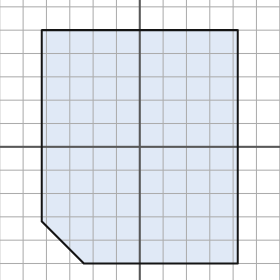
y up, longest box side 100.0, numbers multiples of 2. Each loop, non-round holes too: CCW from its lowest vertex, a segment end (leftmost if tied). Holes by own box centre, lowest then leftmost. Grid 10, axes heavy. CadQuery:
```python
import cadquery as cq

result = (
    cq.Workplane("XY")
    .moveTo(-24.0, -50.0)
    .lineTo(42.0, -50.0)
    .lineTo(42.0, 50.0)
    .lineTo(-42.0, 50.0)
    .lineTo(-42.0, -32.0)
    .close()
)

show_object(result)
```